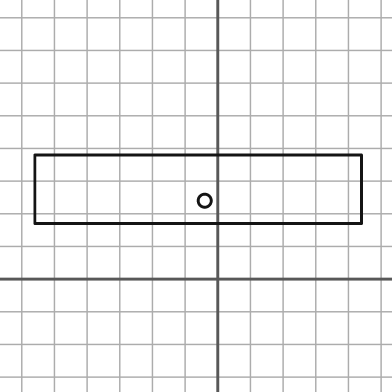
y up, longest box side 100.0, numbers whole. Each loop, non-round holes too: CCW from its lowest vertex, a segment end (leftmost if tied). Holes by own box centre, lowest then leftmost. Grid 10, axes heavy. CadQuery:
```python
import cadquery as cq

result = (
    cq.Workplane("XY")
    .moveTo(-56.0, 17.0)
    .lineTo(44.0, 17.0)
    .lineTo(44.0, 38.0)
    .lineTo(-56.0, 38.0)
    .close()
    .moveTo(-4.0, 24.0)
    .circle(2.0)
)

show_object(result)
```